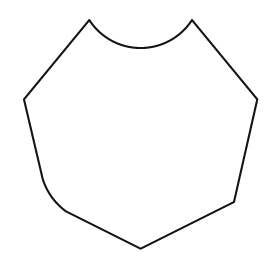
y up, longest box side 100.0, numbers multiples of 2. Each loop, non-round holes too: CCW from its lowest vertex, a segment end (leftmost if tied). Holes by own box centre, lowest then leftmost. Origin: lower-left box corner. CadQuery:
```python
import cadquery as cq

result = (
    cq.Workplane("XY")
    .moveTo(50.0, 0.0)
    .lineTo(90.0, 20.0)
    .lineTo(100.0, 64.0)
    .lineTo(72.0, 98.0)
    .threePointArc((50.0, 86.0), (28.0, 98.0))
    .lineTo(0.0, 64.0)
    .lineTo(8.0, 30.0)
    .threePointArc((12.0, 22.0), (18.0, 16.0))
    .close()
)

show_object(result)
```